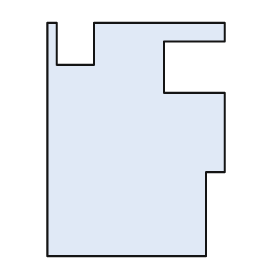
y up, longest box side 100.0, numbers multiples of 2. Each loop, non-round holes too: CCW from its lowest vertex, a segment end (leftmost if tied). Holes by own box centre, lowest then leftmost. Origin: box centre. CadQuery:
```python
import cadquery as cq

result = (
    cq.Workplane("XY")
    .moveTo(-38.0, -50.0)
    .lineTo(30.0, -50.0)
    .lineTo(30.0, -14.0)
    .lineTo(38.0, -14.0)
    .lineTo(38.0, 20.0)
    .lineTo(12.0, 20.0)
    .lineTo(12.0, 42.0)
    .lineTo(38.0, 42.0)
    .lineTo(38.0, 50.0)
    .lineTo(-18.0, 50.0)
    .lineTo(-18.0, 32.0)
    .lineTo(-34.0, 32.0)
    .lineTo(-34.0, 50.0)
    .lineTo(-38.0, 50.0)
    .close()
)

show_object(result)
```